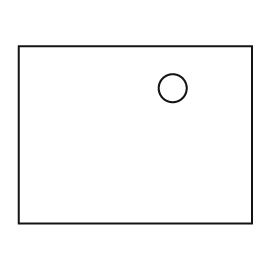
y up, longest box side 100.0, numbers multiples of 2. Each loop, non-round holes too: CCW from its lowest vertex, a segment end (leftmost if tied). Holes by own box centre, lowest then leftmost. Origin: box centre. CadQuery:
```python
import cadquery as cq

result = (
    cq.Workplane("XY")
    .moveTo(-50.0, -38.0)
    .lineTo(50.0, -38.0)
    .lineTo(50.0, 38.0)
    .lineTo(-50.0, 38.0)
    .close()
    .moveTo(16.0, 20.0)
    .circle(6.0)
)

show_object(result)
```